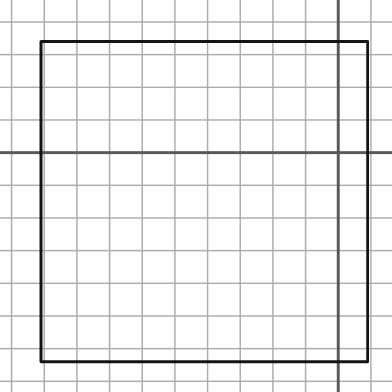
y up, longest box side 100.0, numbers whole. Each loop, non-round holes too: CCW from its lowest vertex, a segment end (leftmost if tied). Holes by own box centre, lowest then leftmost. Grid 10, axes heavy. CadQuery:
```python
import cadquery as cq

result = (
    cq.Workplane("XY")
    .moveTo(-91.0, -64.0)
    .lineTo(9.0, -64.0)
    .lineTo(9.0, 34.0)
    .lineTo(-91.0, 34.0)
    .close()
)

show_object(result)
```